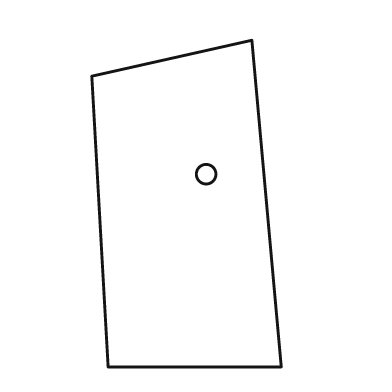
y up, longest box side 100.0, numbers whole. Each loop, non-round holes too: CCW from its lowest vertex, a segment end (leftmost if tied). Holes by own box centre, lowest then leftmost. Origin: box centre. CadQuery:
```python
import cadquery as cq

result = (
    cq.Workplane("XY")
    .moveTo(-24.0, -50.0)
    .lineTo(29.0, -50.0)
    .lineTo(20.0, 50.0)
    .lineTo(-29.0, 39.0)
    .close()
    .moveTo(6.0, 9.0)
    .circle(3.0)
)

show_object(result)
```